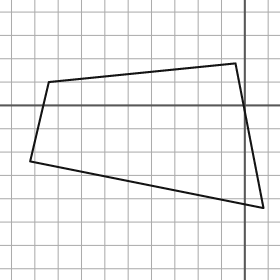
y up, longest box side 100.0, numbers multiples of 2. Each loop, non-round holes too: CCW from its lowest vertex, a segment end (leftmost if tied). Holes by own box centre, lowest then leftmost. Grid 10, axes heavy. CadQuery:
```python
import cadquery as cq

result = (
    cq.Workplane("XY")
    .moveTo(8.0, -44.0)
    .lineTo(-4.0, 18.0)
    .lineTo(-84.0, 10.0)
    .lineTo(-92.0, -24.0)
    .close()
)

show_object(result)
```